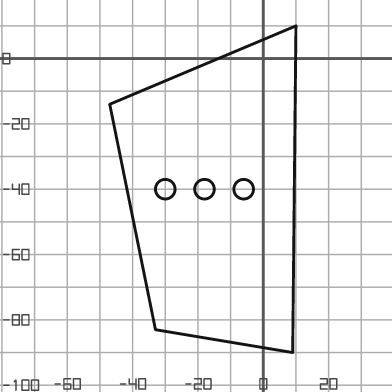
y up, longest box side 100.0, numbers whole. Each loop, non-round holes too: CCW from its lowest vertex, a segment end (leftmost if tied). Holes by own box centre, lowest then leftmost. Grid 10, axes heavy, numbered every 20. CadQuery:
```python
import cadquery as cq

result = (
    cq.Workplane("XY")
    .moveTo(9.0, -90.0)
    .lineTo(10.0, 10.0)
    .lineTo(-47.0, -14.0)
    .lineTo(-33.0, -83.0)
    .close()
    .moveTo(-30.0, -40.0)
    .circle(3.0)
    .moveTo(-18.0, -40.0)
    .circle(3.0)
    .moveTo(-6.0, -40.0)
    .circle(3.0)
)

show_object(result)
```